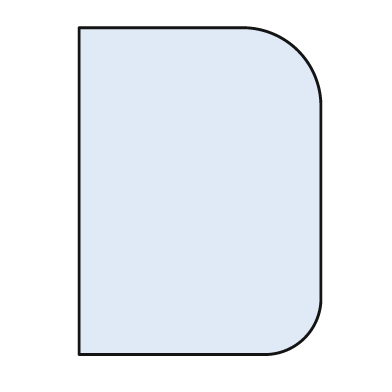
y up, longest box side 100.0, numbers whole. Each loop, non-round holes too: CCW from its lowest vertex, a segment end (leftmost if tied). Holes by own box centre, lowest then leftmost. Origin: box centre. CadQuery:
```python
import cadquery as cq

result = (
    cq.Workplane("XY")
    .moveTo(-37.0, -50.0)
    .lineTo(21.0, -50.0)
    .threePointArc((32.0, -45.0), (37.0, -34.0))
    .lineTo(37.0, 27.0)
    .threePointArc((30.0, 43.0), (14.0, 50.0))
    .lineTo(-37.0, 50.0)
    .close()
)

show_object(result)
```